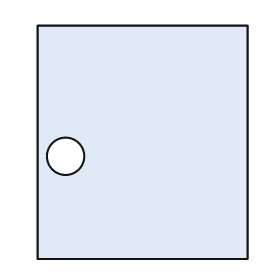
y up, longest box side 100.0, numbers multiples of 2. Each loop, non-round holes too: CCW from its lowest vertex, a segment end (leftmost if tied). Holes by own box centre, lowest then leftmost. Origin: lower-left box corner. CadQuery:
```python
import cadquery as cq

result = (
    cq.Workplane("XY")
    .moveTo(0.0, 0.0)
    .lineTo(90.0, 0.0)
    .lineTo(90.0, 100.0)
    .lineTo(0.0, 100.0)
    .close()
    .moveTo(12.0, 44.0)
    .circle(8.0)
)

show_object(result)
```